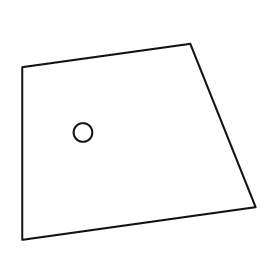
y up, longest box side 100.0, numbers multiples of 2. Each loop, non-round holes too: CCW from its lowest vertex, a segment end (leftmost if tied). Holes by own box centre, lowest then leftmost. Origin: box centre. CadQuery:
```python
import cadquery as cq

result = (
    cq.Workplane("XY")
    .moveTo(-50.0, -42.0)
    .lineTo(50.0, -28.0)
    .lineTo(22.0, 42.0)
    .lineTo(-50.0, 32.0)
    .close()
    .moveTo(-24.0, 4.0)
    .circle(4.0)
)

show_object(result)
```